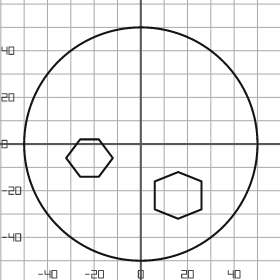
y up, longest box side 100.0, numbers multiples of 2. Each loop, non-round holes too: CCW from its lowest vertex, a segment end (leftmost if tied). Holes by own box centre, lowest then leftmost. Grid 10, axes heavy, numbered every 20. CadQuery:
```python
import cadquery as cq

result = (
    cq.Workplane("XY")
    .moveTo(0.0, 0.0)
    .circle(50.0)
    .moveTo(16.0, -32.0)
    .lineTo(26.0, -28.0)
    .lineTo(26.0, -16.0)
    .lineTo(16.0, -12.0)
    .lineTo(6.0, -16.0)
    .lineTo(6.0, -28.0)
    .close()
    .moveTo(-26.0, -14.0)
    .lineTo(-18.0, -14.0)
    .lineTo(-12.0, -6.0)
    .lineTo(-18.0, 2.0)
    .lineTo(-26.0, 2.0)
    .lineTo(-32.0, -6.0)
    .close()
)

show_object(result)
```